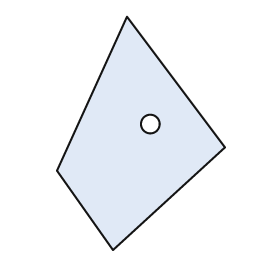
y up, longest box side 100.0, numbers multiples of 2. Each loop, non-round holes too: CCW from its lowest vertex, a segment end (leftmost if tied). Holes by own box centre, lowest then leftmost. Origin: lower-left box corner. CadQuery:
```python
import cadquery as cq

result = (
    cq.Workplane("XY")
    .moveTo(24.0, 0.0)
    .lineTo(72.0, 44.0)
    .lineTo(30.0, 100.0)
    .lineTo(0.0, 34.0)
    .close()
    .moveTo(40.0, 54.0)
    .circle(4.0)
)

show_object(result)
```